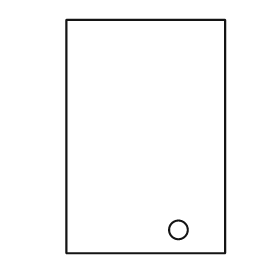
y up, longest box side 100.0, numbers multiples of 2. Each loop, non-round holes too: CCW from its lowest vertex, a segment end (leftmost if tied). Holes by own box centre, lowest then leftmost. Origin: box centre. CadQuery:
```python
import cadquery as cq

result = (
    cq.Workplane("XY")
    .moveTo(-34.0, -50.0)
    .lineTo(34.0, -50.0)
    .lineTo(34.0, 50.0)
    .lineTo(-34.0, 50.0)
    .close()
    .moveTo(14.0, -40.0)
    .circle(4.0)
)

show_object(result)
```